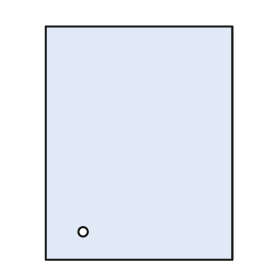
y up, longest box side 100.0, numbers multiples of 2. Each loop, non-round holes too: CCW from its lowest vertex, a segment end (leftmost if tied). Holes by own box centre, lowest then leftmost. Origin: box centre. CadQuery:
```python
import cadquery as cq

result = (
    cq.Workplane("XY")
    .moveTo(-40.0, -50.0)
    .lineTo(40.0, -50.0)
    .lineTo(40.0, 50.0)
    .lineTo(-40.0, 50.0)
    .close()
    .moveTo(-24.0, -38.0)
    .circle(2.0)
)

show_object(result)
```